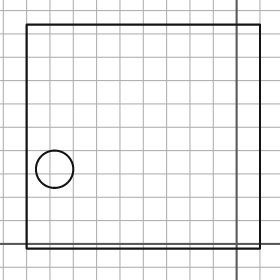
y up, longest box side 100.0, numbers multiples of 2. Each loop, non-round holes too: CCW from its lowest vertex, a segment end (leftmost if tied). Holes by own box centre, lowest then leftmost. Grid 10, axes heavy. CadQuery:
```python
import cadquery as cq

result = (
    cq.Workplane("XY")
    .moveTo(-90.0, -2.0)
    .lineTo(10.0, -2.0)
    .lineTo(10.0, 94.0)
    .lineTo(-90.0, 94.0)
    .close()
    .moveTo(-78.0, 32.0)
    .circle(8.0)
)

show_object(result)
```